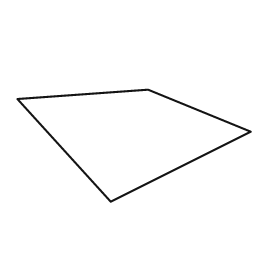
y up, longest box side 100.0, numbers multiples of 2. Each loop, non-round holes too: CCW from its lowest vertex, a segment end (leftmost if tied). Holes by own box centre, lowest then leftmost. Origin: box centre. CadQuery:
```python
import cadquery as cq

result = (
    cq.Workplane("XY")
    .moveTo(-10.0, -24.0)
    .lineTo(50.0, 6.0)
    .lineTo(6.0, 24.0)
    .lineTo(-50.0, 20.0)
    .close()
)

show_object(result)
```